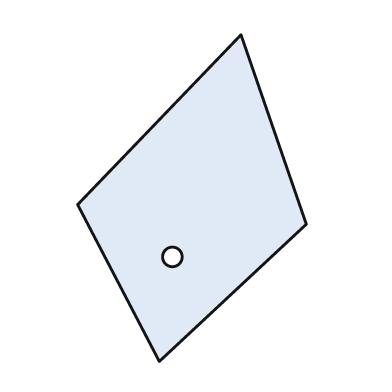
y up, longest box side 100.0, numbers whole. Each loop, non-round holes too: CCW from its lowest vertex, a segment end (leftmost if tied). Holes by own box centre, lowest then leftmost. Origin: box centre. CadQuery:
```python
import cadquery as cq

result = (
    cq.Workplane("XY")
    .moveTo(-10.0, -50.0)
    .lineTo(35.0, -8.0)
    .lineTo(15.0, 50.0)
    .lineTo(-35.0, -2.0)
    .close()
    .moveTo(-6.0, -18.0)
    .circle(3.0)
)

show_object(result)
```